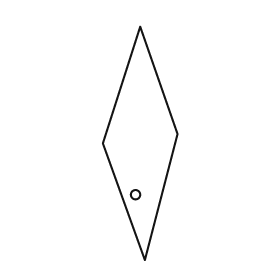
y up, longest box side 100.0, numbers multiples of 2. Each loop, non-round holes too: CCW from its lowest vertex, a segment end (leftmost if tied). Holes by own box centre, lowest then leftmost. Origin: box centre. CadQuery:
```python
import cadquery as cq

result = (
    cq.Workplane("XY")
    .moveTo(2.0, -50.0)
    .lineTo(16.0, 4.0)
    .lineTo(0.0, 50.0)
    .lineTo(-16.0, 0.0)
    .close()
    .moveTo(-2.0, -22.0)
    .circle(2.0)
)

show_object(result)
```